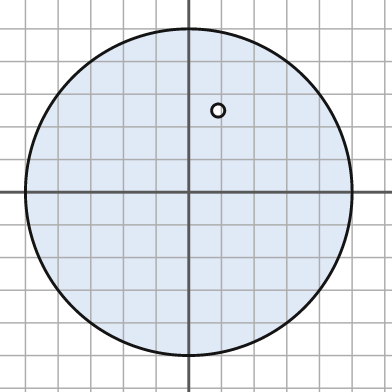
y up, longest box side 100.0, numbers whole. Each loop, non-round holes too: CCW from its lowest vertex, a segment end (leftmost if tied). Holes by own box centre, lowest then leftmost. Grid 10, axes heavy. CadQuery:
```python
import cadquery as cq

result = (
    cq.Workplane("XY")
    .moveTo(0.0, 0.0)
    .circle(50.0)
    .moveTo(9.0, 25.0)
    .circle(2.0)
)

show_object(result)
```